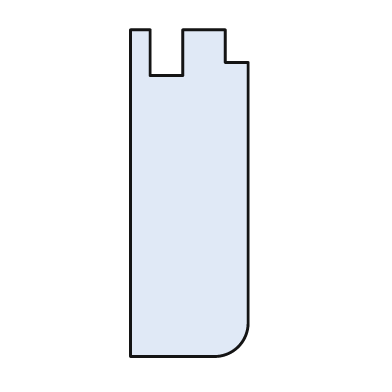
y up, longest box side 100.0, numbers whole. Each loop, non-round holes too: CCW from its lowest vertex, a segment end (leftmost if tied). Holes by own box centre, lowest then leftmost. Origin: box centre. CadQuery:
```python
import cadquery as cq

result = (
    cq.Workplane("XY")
    .moveTo(-18.0, -50.0)
    .lineTo(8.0, -50.0)
    .threePointArc((15.0, -47.0), (18.0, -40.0))
    .lineTo(18.0, 40.0)
    .lineTo(11.0, 40.0)
    .lineTo(11.0, 50.0)
    .lineTo(-2.0, 50.0)
    .lineTo(-2.0, 36.0)
    .lineTo(-12.0, 36.0)
    .lineTo(-12.0, 50.0)
    .lineTo(-18.0, 50.0)
    .close()
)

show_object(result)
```